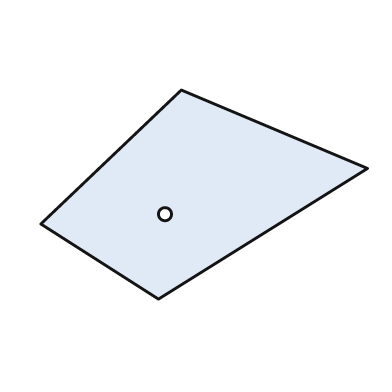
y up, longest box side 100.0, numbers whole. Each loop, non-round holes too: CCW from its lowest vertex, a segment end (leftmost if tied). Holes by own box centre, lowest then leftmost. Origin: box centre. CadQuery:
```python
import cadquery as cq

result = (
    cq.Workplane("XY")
    .moveTo(-14.0, -32.0)
    .lineTo(50.0, 8.0)
    .lineTo(-7.0, 32.0)
    .lineTo(-50.0, -9.0)
    .close()
    .moveTo(-12.0, -6.0)
    .circle(2.0)
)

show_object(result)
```